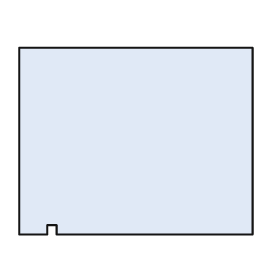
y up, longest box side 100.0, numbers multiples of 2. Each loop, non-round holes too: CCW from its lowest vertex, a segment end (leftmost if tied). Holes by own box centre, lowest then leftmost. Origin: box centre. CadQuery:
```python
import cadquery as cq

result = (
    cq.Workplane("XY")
    .moveTo(-50.0, -40.0)
    .lineTo(-38.0, -40.0)
    .lineTo(-38.0, -36.0)
    .lineTo(-34.0, -36.0)
    .lineTo(-34.0, -40.0)
    .lineTo(50.0, -40.0)
    .lineTo(50.0, 40.0)
    .lineTo(-50.0, 40.0)
    .close()
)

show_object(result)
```